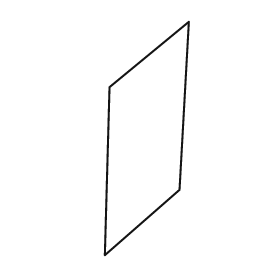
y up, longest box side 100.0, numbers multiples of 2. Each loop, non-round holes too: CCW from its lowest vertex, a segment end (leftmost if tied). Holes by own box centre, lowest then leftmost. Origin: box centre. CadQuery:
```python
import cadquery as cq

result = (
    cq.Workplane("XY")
    .moveTo(-18.0, -50.0)
    .lineTo(14.0, -22.0)
    .lineTo(18.0, 50.0)
    .lineTo(-16.0, 22.0)
    .close()
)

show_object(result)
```